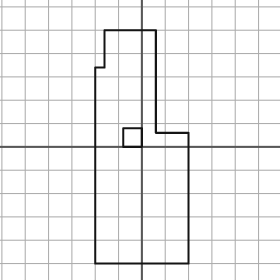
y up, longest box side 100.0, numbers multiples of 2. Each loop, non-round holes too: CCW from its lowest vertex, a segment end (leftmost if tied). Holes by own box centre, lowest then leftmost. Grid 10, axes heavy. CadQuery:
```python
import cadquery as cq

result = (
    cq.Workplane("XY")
    .moveTo(-20.0, -50.0)
    .lineTo(20.0, -50.0)
    .lineTo(20.0, 6.0)
    .lineTo(6.0, 6.0)
    .lineTo(6.0, 50.0)
    .lineTo(-16.0, 50.0)
    .lineTo(-16.0, 34.0)
    .lineTo(-20.0, 34.0)
    .close()
    .moveTo(-8.0, 0.0)
    .lineTo(0.0, 0.0)
    .lineTo(0.0, 8.0)
    .lineTo(-8.0, 8.0)
    .close()
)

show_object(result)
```